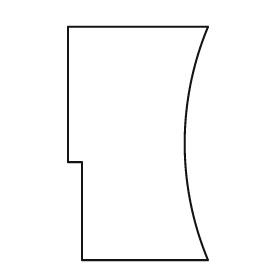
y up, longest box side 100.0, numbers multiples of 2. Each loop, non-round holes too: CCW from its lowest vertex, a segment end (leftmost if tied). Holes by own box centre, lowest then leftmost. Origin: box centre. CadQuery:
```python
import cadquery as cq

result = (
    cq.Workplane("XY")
    .moveTo(-24.0, -50.0)
    .lineTo(30.0, -50.0)
    .threePointArc((20.0, 0.0), (30.0, 50.0))
    .lineTo(-30.0, 50.0)
    .lineTo(-30.0, -8.0)
    .lineTo(-24.0, -8.0)
    .close()
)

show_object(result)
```